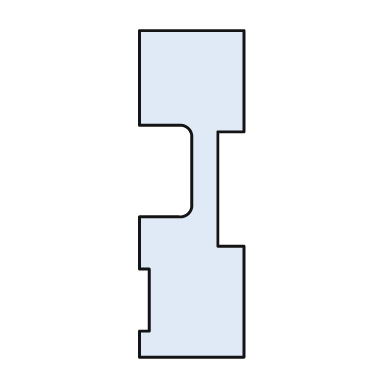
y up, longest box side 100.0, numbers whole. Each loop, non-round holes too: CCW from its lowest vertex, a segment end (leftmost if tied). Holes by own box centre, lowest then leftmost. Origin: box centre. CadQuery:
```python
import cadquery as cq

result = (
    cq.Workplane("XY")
    .moveTo(-16.0, -50.0)
    .lineTo(16.0, -50.0)
    .lineTo(16.0, -16.0)
    .lineTo(8.0, -16.0)
    .lineTo(8.0, 19.0)
    .lineTo(16.0, 19.0)
    .lineTo(16.0, 50.0)
    .lineTo(-16.0, 50.0)
    .lineTo(-16.0, 21.0)
    .lineTo(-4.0, 21.0)
    .threePointArc((-1.0, 20.0), (0.0, 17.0))
    .lineTo(0.0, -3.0)
    .threePointArc((-1.0, -6.0), (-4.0, -7.0))
    .lineTo(-16.0, -7.0)
    .lineTo(-16.0, -23.0)
    .lineTo(-13.0, -23.0)
    .lineTo(-13.0, -42.0)
    .lineTo(-16.0, -42.0)
    .close()
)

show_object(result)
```